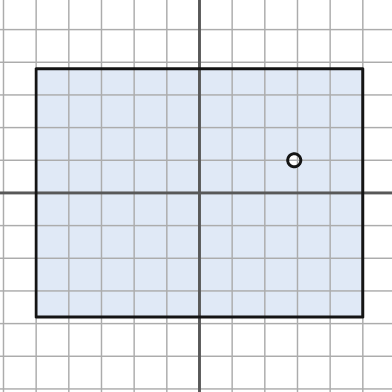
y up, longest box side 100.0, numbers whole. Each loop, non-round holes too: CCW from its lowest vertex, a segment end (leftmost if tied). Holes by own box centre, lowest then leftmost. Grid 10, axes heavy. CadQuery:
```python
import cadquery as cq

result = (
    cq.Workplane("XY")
    .moveTo(-50.0, -38.0)
    .lineTo(50.0, -38.0)
    .lineTo(50.0, 38.0)
    .lineTo(-50.0, 38.0)
    .close()
    .moveTo(29.0, 10.0)
    .circle(2.0)
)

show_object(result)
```